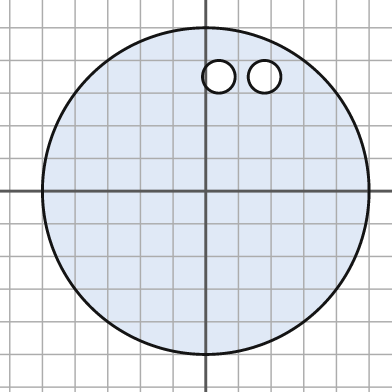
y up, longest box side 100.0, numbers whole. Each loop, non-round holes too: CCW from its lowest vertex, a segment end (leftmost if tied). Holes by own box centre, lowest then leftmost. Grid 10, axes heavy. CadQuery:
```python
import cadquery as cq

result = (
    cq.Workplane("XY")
    .moveTo(0.0, 0.0)
    .circle(50.0)
    .moveTo(4.0, 35.0)
    .circle(5.0)
    .moveTo(18.0, 35.0)
    .circle(5.0)
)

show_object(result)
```